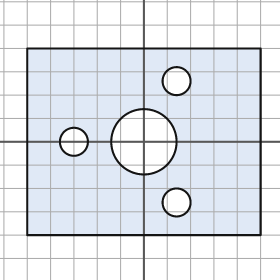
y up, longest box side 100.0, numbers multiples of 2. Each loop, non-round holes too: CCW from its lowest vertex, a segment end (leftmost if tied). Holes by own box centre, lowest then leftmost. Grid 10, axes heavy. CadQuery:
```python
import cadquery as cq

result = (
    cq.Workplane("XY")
    .moveTo(-50.0, -40.0)
    .lineTo(50.0, -40.0)
    .lineTo(50.0, 40.0)
    .lineTo(-50.0, 40.0)
    .close()
    .moveTo(14.0, -26.0)
    .circle(6.0)
    .moveTo(-30.0, 0.0)
    .circle(6.0)
    .moveTo(0.0, 0.0)
    .circle(14.0)
    .moveTo(14.0, 26.0)
    .circle(6.0)
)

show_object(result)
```